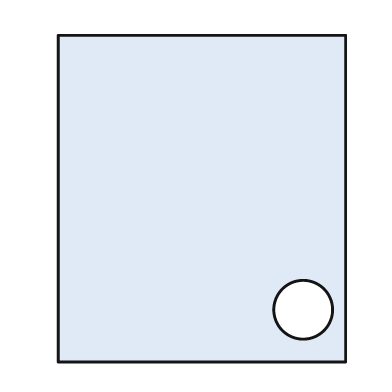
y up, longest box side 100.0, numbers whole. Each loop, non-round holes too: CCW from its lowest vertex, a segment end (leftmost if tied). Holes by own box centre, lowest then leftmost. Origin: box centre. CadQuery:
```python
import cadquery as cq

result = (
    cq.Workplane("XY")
    .moveTo(-44.0, -50.0)
    .lineTo(44.0, -50.0)
    .lineTo(44.0, 50.0)
    .lineTo(-44.0, 50.0)
    .close()
    .moveTo(31.0, -34.0)
    .circle(9.0)
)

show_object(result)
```